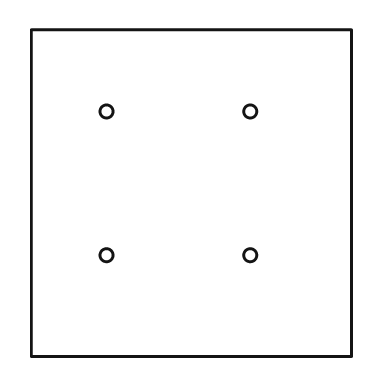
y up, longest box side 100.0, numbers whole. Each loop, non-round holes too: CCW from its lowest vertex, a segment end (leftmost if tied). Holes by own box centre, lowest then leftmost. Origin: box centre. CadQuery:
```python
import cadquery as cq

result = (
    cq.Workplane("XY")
    .moveTo(-49.0, -50.0)
    .lineTo(49.0, -50.0)
    .lineTo(49.0, 50.0)
    .lineTo(-49.0, 50.0)
    .close()
    .moveTo(-26.0, -19.0)
    .circle(2.0)
    .moveTo(18.0, -19.0)
    .circle(2.0)
    .moveTo(-26.0, 25.0)
    .circle(2.0)
    .moveTo(18.0, 25.0)
    .circle(2.0)
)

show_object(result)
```